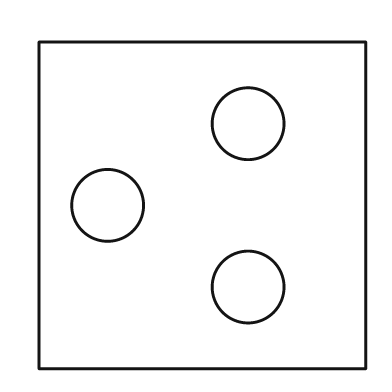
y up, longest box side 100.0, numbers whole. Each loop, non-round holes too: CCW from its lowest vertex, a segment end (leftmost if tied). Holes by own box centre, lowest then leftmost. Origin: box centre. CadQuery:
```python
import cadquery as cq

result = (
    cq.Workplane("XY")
    .moveTo(-50.0, -50.0)
    .lineTo(50.0, -50.0)
    .lineTo(50.0, 50.0)
    .lineTo(-50.0, 50.0)
    .close()
    .moveTo(14.0, -25.0)
    .circle(11.0)
    .moveTo(-29.0, 0.0)
    .circle(11.0)
    .moveTo(14.0, 25.0)
    .circle(11.0)
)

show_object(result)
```